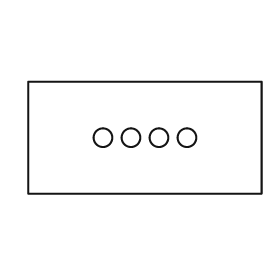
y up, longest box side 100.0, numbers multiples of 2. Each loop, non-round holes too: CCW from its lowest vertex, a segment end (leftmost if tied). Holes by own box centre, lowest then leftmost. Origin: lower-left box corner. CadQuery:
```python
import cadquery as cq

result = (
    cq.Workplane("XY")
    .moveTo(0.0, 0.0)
    .lineTo(100.0, 0.0)
    .lineTo(100.0, 48.0)
    .lineTo(0.0, 48.0)
    .close()
    .moveTo(32.0, 24.0)
    .circle(4.0)
    .moveTo(44.0, 24.0)
    .circle(4.0)
    .moveTo(56.0, 24.0)
    .circle(4.0)
    .moveTo(68.0, 24.0)
    .circle(4.0)
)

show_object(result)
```